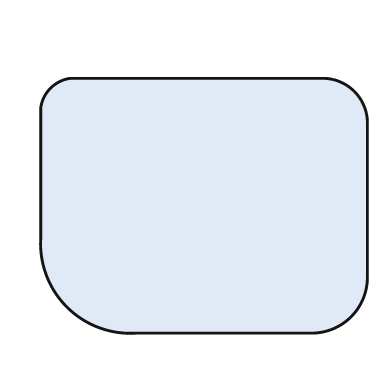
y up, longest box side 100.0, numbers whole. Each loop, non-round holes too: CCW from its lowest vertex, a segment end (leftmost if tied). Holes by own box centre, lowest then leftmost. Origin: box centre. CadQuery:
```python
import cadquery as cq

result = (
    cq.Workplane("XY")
    .moveTo(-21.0, -39.0)
    .lineTo(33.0, -39.0)
    .threePointArc((45.0, -34.0), (50.0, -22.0))
    .lineTo(50.0, 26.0)
    .threePointArc((46.0, 35.0), (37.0, 39.0))
    .lineTo(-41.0, 39.0)
    .threePointArc((-47.0, 36.0), (-50.0, 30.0))
    .lineTo(-50.0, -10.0)
    .threePointArc((-42.0, -31.0), (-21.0, -39.0))
    .close()
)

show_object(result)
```